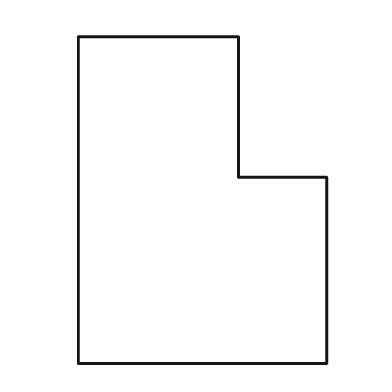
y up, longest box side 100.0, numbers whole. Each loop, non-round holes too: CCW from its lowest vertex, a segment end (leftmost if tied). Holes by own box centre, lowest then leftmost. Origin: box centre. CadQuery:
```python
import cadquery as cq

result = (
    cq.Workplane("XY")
    .moveTo(-38.0, -50.0)
    .lineTo(38.0, -50.0)
    .lineTo(38.0, 7.0)
    .lineTo(11.0, 7.0)
    .lineTo(11.0, 50.0)
    .lineTo(-38.0, 50.0)
    .close()
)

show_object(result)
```